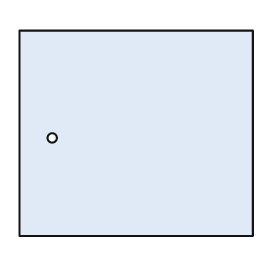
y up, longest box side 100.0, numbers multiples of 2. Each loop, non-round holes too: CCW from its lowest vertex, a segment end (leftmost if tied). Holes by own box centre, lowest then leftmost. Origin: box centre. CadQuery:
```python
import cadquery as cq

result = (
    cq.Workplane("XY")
    .moveTo(-50.0, -44.0)
    .lineTo(50.0, -44.0)
    .lineTo(50.0, 44.0)
    .lineTo(-50.0, 44.0)
    .close()
    .moveTo(-36.0, -2.0)
    .circle(2.0)
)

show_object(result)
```